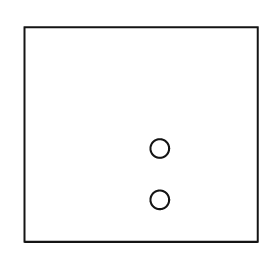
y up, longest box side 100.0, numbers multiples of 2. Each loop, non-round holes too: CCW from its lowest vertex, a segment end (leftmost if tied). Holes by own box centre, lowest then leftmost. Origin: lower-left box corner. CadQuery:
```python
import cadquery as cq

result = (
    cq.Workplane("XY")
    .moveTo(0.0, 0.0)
    .lineTo(100.0, 0.0)
    .lineTo(100.0, 92.0)
    .lineTo(0.0, 92.0)
    .close()
    .moveTo(58.0, 18.0)
    .circle(4.0)
    .moveTo(58.0, 40.0)
    .circle(4.0)
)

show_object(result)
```